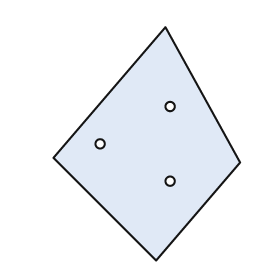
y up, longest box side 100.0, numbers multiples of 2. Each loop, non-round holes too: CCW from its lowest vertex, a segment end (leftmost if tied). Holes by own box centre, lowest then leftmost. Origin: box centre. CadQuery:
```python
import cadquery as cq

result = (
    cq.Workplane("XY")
    .moveTo(4.0, -50.0)
    .lineTo(40.0, -8.0)
    .lineTo(8.0, 50.0)
    .lineTo(-40.0, -6.0)
    .close()
    .moveTo(10.0, -16.0)
    .circle(2.0)
    .moveTo(-20.0, 0.0)
    .circle(2.0)
    .moveTo(10.0, 16.0)
    .circle(2.0)
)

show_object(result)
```